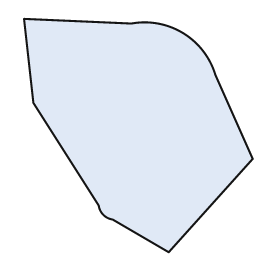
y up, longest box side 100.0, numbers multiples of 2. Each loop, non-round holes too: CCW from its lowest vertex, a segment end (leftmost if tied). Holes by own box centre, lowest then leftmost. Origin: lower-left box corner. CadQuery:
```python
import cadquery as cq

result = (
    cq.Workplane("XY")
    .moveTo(62.0, 0.0)
    .lineTo(98.0, 40.0)
    .lineTo(82.0, 76.0)
    .threePointArc((68.0, 94.0), (46.0, 98.0))
    .lineTo(0.0, 100.0)
    .lineTo(4.0, 64.0)
    .lineTo(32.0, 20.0)
    .threePointArc((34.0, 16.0), (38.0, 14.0))
    .close()
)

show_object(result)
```